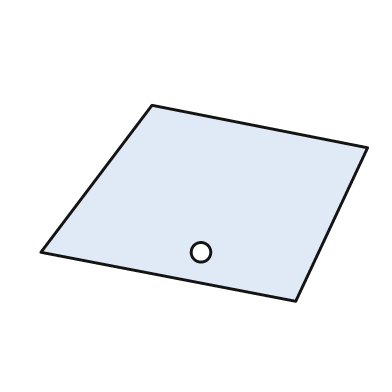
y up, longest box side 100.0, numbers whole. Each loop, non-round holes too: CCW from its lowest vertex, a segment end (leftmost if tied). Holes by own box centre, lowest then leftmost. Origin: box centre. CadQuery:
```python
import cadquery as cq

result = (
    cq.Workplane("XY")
    .moveTo(28.0, -30.0)
    .lineTo(50.0, 17.0)
    .lineTo(-16.0, 30.0)
    .lineTo(-50.0, -15.0)
    .close()
    .moveTo(-1.0, -15.0)
    .circle(3.0)
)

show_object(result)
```